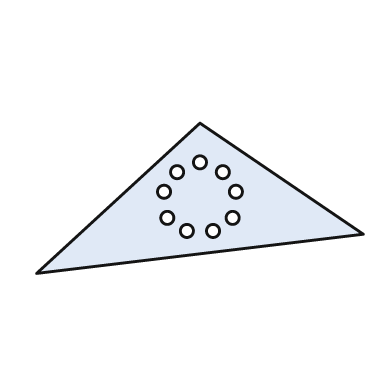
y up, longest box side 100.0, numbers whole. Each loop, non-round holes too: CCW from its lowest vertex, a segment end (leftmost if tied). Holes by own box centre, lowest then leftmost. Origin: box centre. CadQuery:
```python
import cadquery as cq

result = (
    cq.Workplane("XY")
    .moveTo(-50.0, -23.0)
    .lineTo(50.0, -11.0)
    .lineTo(0.0, 23.0)
    .close()
    .moveTo(-4.0, -10.0)
    .circle(2.0)
    .moveTo(4.0, -10.0)
    .circle(2.0)
    .moveTo(-10.0, -6.0)
    .circle(2.0)
    .moveTo(10.0, -6.0)
    .circle(2.0)
    .moveTo(-11.0, 2.0)
    .circle(2.0)
    .moveTo(11.0, 2.0)
    .circle(2.0)
    .moveTo(-7.0, 8.0)
    .circle(2.0)
    .moveTo(7.0, 8.0)
    .circle(2.0)
    .moveTo(0.0, 11.0)
    .circle(2.0)
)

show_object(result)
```